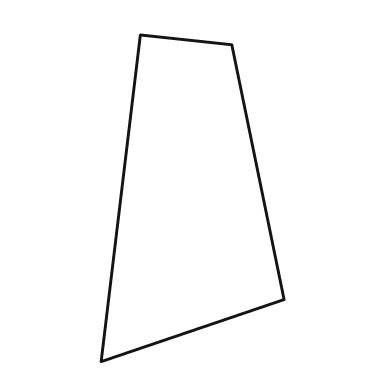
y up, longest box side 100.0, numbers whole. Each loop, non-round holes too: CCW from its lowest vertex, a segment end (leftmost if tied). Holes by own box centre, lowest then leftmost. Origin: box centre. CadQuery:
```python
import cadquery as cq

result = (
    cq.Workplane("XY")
    .moveTo(-28.0, -50.0)
    .lineTo(28.0, -31.0)
    .lineTo(12.0, 47.0)
    .lineTo(-16.0, 50.0)
    .close()
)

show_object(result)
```